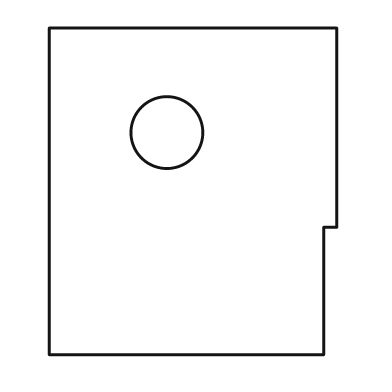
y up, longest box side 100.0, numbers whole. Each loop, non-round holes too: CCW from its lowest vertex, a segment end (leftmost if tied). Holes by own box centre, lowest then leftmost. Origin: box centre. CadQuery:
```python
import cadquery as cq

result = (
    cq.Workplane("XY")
    .moveTo(-44.0, -50.0)
    .lineTo(40.0, -50.0)
    .lineTo(40.0, -11.0)
    .lineTo(44.0, -11.0)
    .lineTo(44.0, 50.0)
    .lineTo(-44.0, 50.0)
    .close()
    .moveTo(-8.0, 18.0)
    .circle(11.0)
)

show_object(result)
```